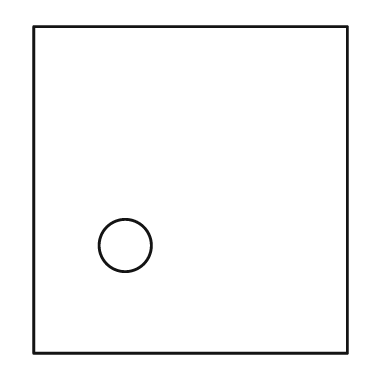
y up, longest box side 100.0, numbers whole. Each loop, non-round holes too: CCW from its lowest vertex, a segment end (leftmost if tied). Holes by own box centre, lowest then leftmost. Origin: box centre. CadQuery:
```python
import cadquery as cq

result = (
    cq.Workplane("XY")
    .moveTo(-48.0, -50.0)
    .lineTo(48.0, -50.0)
    .lineTo(48.0, 50.0)
    .lineTo(-48.0, 50.0)
    .close()
    .moveTo(-20.0, -17.0)
    .circle(8.0)
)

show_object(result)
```